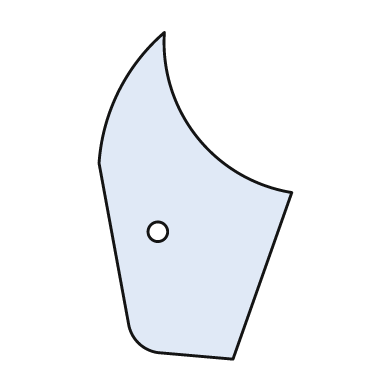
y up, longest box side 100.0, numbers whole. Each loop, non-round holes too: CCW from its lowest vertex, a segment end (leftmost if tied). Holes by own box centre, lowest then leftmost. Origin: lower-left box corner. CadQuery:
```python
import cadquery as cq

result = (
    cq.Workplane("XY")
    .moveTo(41.0, 0.0)
    .lineTo(59.0, 51.0)
    .threePointArc((30.0, 68.0), (20.0, 100.0))
    .threePointArc((6.0, 82.0), (0.0, 60.0))
    .lineTo(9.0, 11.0)
    .threePointArc((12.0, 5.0), (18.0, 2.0))
    .close()
    .moveTo(18.0, 39.0)
    .circle(3.0)
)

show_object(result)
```